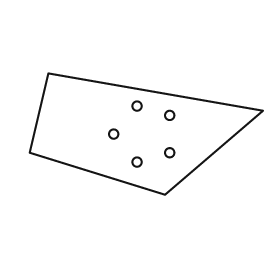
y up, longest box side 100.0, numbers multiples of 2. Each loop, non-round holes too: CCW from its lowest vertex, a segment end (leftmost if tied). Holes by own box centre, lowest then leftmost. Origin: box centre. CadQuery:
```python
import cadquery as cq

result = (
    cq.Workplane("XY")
    .moveTo(8.0, -26.0)
    .lineTo(50.0, 10.0)
    .lineTo(-42.0, 26.0)
    .lineTo(-50.0, -8.0)
    .close()
    .moveTo(-4.0, -12.0)
    .circle(2.0)
    .moveTo(10.0, -8.0)
    .circle(2.0)
    .moveTo(-14.0, 0.0)
    .circle(2.0)
    .moveTo(10.0, 8.0)
    .circle(2.0)
    .moveTo(-4.0, 12.0)
    .circle(2.0)
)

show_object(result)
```